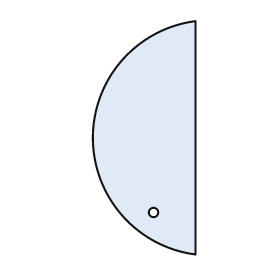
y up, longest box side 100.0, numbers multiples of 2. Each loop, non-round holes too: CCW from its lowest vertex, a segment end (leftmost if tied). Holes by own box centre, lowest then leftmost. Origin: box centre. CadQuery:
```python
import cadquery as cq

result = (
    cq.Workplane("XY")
    .moveTo(22.0, -50.0)
    .lineTo(22.0, 50.0)
    .threePointArc((-22.0, 0.0), (22.0, -50.0))
    .close()
    .moveTo(4.0, -32.0)
    .circle(2.0)
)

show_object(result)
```